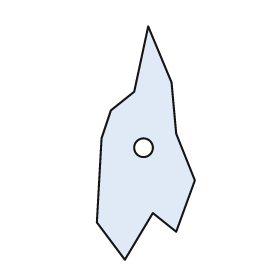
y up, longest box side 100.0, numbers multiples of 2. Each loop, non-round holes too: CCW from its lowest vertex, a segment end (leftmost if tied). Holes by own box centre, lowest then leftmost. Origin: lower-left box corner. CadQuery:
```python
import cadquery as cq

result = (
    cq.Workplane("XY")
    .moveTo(12.0, 0.0)
    .lineTo(24.0, 20.0)
    .lineTo(34.0, 12.0)
    .lineTo(42.0, 34.0)
    .lineTo(34.0, 54.0)
    .lineTo(32.0, 76.0)
    .lineTo(22.0, 100.0)
    .lineTo(16.0, 72.0)
    .lineTo(6.0, 64.0)
    .lineTo(2.0, 52.0)
    .lineTo(0.0, 16.0)
    .close()
    .moveTo(20.0, 48.0)
    .circle(4.0)
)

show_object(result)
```